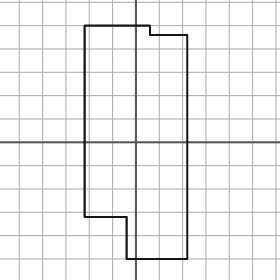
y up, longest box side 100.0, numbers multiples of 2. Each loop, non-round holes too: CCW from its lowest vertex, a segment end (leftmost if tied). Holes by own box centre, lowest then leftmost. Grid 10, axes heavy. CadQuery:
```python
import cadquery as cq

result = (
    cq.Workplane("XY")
    .moveTo(-4.0, -50.0)
    .lineTo(22.0, -50.0)
    .lineTo(22.0, 46.0)
    .lineTo(6.0, 46.0)
    .lineTo(6.0, 50.0)
    .lineTo(-22.0, 50.0)
    .lineTo(-22.0, -32.0)
    .lineTo(-4.0, -32.0)
    .close()
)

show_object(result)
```